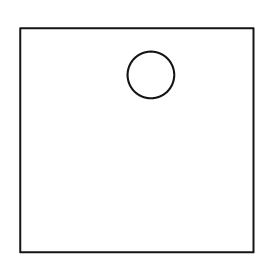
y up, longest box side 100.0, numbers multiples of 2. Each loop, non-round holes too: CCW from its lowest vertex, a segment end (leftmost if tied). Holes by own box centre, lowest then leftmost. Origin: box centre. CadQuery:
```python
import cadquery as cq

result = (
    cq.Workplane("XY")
    .moveTo(-50.0, -48.0)
    .lineTo(50.0, -48.0)
    .lineTo(50.0, 48.0)
    .lineTo(-50.0, 48.0)
    .close()
    .moveTo(6.0, 28.0)
    .circle(10.0)
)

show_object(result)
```